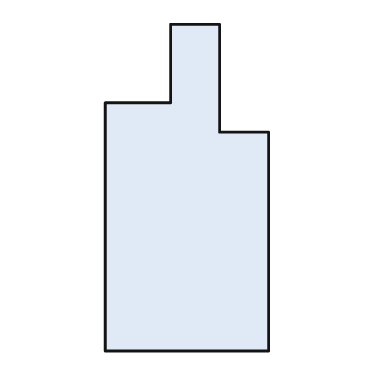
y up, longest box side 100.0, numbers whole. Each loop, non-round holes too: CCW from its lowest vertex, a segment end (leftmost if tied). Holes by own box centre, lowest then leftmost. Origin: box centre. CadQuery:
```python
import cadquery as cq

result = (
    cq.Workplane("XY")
    .moveTo(-25.0, -50.0)
    .lineTo(25.0, -50.0)
    .lineTo(25.0, 17.0)
    .lineTo(10.0, 17.0)
    .lineTo(10.0, 50.0)
    .lineTo(-5.0, 50.0)
    .lineTo(-5.0, 26.0)
    .lineTo(-25.0, 26.0)
    .close()
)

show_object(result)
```